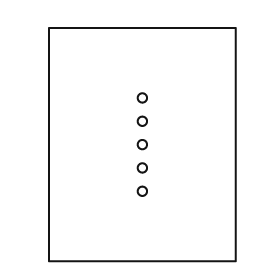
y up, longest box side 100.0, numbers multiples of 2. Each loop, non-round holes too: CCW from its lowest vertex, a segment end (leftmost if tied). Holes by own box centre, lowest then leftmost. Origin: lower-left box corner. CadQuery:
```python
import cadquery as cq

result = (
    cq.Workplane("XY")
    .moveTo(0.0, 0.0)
    .lineTo(80.0, 0.0)
    .lineTo(80.0, 100.0)
    .lineTo(0.0, 100.0)
    .close()
    .moveTo(40.0, 30.0)
    .circle(2.0)
    .moveTo(40.0, 40.0)
    .circle(2.0)
    .moveTo(40.0, 50.0)
    .circle(2.0)
    .moveTo(40.0, 60.0)
    .circle(2.0)
    .moveTo(40.0, 70.0)
    .circle(2.0)
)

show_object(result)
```